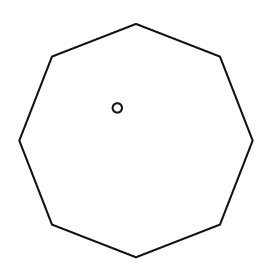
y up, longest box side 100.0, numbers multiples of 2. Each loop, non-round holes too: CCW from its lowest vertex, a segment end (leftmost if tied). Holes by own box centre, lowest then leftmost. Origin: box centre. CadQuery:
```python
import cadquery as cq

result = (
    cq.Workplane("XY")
    .moveTo(0.0, -50.0)
    .lineTo(36.0, -36.0)
    .lineTo(50.0, 0.0)
    .lineTo(36.0, 36.0)
    .lineTo(0.0, 50.0)
    .lineTo(-36.0, 36.0)
    .lineTo(-50.0, 0.0)
    .lineTo(-36.0, -36.0)
    .close()
    .moveTo(-8.0, 14.0)
    .circle(2.0)
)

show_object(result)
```